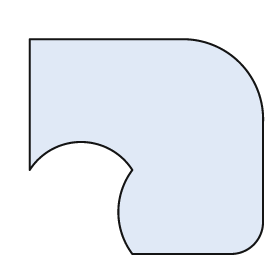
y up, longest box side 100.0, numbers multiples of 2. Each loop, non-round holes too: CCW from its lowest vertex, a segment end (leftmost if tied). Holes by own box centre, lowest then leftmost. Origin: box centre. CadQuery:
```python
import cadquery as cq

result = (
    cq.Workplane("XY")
    .moveTo(-6.0, -46.0)
    .lineTo(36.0, -46.0)
    .threePointArc((46.0, -42.0), (50.0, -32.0))
    .lineTo(50.0, 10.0)
    .threePointArc((40.0, 36.0), (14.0, 46.0))
    .lineTo(-50.0, 46.0)
    .lineTo(-50.0, -10.0)
    .threePointArc((-28.0, 2.0), (-6.0, -10.0))
    .threePointArc((-12.0, -28.0), (-6.0, -46.0))
    .close()
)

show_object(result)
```